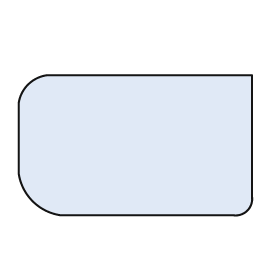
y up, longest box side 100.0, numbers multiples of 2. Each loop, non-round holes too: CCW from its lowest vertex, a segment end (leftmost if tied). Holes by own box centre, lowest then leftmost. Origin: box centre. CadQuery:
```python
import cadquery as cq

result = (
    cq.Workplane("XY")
    .moveTo(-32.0, -30.0)
    .lineTo(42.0, -30.0)
    .threePointArc((48.0, -28.0), (50.0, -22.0))
    .lineTo(50.0, 30.0)
    .lineTo(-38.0, 30.0)
    .threePointArc((-46.0, 26.0), (-50.0, 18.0))
    .lineTo(-50.0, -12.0)
    .threePointArc((-44.0, -24.0), (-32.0, -30.0))
    .close()
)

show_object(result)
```